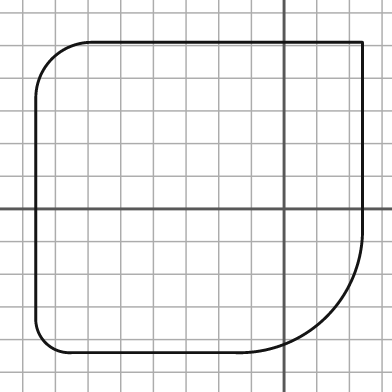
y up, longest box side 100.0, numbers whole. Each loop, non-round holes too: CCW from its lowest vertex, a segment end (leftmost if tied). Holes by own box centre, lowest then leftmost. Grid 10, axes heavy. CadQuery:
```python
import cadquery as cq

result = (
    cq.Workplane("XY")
    .moveTo(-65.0, -44.0)
    .lineTo(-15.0, -44.0)
    .threePointArc((13.0, -33.0), (24.0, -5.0))
    .lineTo(24.0, 51.0)
    .lineTo(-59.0, 51.0)
    .threePointArc((-71.0, 46.0), (-76.0, 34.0))
    .lineTo(-76.0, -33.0)
    .threePointArc((-73.0, -41.0), (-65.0, -44.0))
    .close()
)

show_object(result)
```